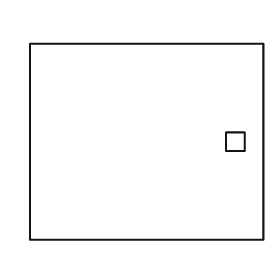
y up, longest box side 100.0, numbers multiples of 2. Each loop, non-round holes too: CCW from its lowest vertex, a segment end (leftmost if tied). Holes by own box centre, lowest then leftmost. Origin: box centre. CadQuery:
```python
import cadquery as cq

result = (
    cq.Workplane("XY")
    .moveTo(-50.0, -42.0)
    .lineTo(50.0, -42.0)
    .lineTo(50.0, 42.0)
    .lineTo(-50.0, 42.0)
    .close()
    .moveTo(34.0, -4.0)
    .lineTo(42.0, -4.0)
    .lineTo(42.0, 4.0)
    .lineTo(34.0, 4.0)
    .close()
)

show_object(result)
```